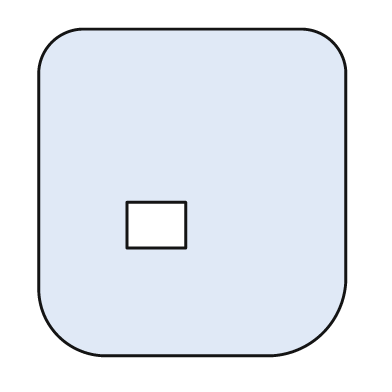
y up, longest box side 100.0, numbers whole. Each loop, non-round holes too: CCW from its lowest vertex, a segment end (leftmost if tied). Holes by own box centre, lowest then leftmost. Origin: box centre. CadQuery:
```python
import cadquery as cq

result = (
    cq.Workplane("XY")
    .moveTo(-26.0, -50.0)
    .lineTo(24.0, -50.0)
    .threePointArc((40.0, -43.0), (47.0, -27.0))
    .lineTo(47.0, 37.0)
    .threePointArc((43.0, 46.0), (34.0, 50.0))
    .lineTo(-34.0, 50.0)
    .threePointArc((-43.0, 46.0), (-47.0, 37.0))
    .lineTo(-47.0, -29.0)
    .threePointArc((-41.0, -44.0), (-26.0, -50.0))
    .close()
    .moveTo(-20.0, -17.0)
    .lineTo(-2.0, -17.0)
    .lineTo(-2.0, -3.0)
    .lineTo(-20.0, -3.0)
    .close()
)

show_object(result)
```